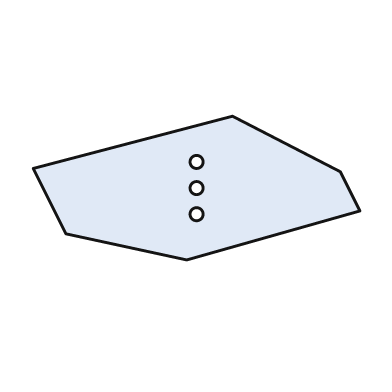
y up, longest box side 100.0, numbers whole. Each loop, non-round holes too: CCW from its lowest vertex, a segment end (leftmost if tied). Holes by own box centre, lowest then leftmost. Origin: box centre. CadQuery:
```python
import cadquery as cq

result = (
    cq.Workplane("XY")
    .moveTo(-3.0, -22.0)
    .lineTo(50.0, -7.0)
    .lineTo(44.0, 5.0)
    .lineTo(11.0, 22.0)
    .lineTo(-50.0, 6.0)
    .lineTo(-40.0, -14.0)
    .close()
    .moveTo(0.0, -8.0)
    .circle(2.0)
    .moveTo(0.0, 0.0)
    .circle(2.0)
    .moveTo(0.0, 8.0)
    .circle(2.0)
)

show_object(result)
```